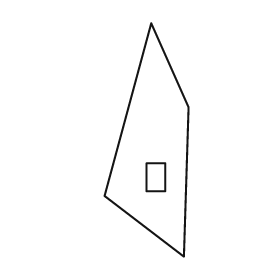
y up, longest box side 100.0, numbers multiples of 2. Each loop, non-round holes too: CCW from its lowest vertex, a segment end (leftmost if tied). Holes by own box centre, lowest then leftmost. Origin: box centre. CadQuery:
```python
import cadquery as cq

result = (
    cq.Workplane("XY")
    .moveTo(16.0, -50.0)
    .lineTo(18.0, 14.0)
    .lineTo(2.0, 50.0)
    .lineTo(-18.0, -24.0)
    .close()
    .moveTo(0.0, -22.0)
    .lineTo(8.0, -22.0)
    .lineTo(8.0, -10.0)
    .lineTo(0.0, -10.0)
    .close()
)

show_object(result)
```